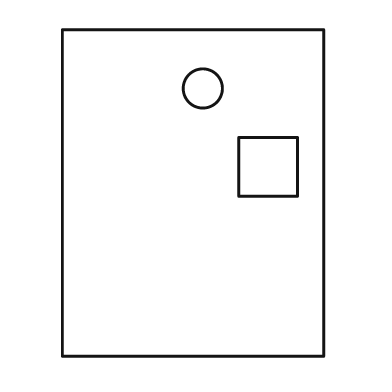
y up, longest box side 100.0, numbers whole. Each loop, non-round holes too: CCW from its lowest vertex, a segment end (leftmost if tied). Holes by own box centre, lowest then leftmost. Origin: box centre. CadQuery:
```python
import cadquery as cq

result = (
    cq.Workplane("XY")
    .moveTo(-40.0, -50.0)
    .lineTo(40.0, -50.0)
    .lineTo(40.0, 50.0)
    .lineTo(-40.0, 50.0)
    .close()
    .moveTo(14.0, -1.0)
    .lineTo(32.0, -1.0)
    .lineTo(32.0, 17.0)
    .lineTo(14.0, 17.0)
    .close()
    .moveTo(3.0, 32.0)
    .circle(6.0)
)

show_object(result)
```